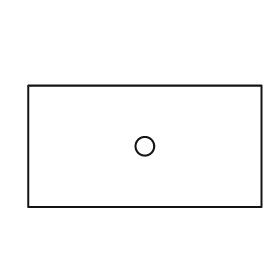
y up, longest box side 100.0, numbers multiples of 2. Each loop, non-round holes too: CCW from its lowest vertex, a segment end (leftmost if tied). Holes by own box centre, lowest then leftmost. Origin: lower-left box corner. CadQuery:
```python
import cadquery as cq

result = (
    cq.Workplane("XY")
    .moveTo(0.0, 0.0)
    .lineTo(100.0, 0.0)
    .lineTo(100.0, 52.0)
    .lineTo(0.0, 52.0)
    .close()
    .moveTo(50.0, 26.0)
    .circle(4.0)
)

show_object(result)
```